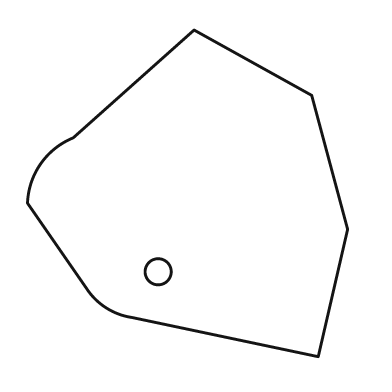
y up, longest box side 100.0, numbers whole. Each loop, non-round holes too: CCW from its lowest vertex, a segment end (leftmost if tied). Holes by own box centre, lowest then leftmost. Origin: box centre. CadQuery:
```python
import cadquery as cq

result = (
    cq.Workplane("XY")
    .moveTo(40.0, -50.0)
    .lineTo(49.0, -11.0)
    .lineTo(38.0, 30.0)
    .lineTo(2.0, 50.0)
    .lineTo(-35.0, 17.0)
    .threePointArc((-45.0, 9.0), (-49.0, -3.0))
    .lineTo(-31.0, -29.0)
    .threePointArc((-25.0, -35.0), (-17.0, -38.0))
    .close()
    .moveTo(-9.0, -24.0)
    .circle(4.0)
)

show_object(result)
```